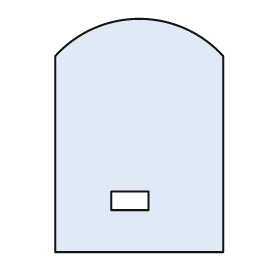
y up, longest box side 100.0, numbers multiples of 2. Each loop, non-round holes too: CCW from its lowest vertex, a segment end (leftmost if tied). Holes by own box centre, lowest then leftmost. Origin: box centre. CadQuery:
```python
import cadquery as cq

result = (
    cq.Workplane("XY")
    .moveTo(-36.0, -50.0)
    .lineTo(36.0, -50.0)
    .lineTo(36.0, 34.0)
    .threePointArc((0.0, 50.0), (-36.0, 34.0))
    .close()
    .moveTo(-12.0, -32.0)
    .lineTo(4.0, -32.0)
    .lineTo(4.0, -24.0)
    .lineTo(-12.0, -24.0)
    .close()
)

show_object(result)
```